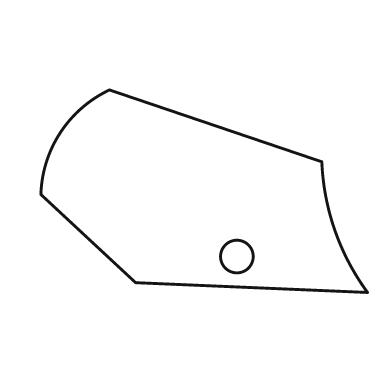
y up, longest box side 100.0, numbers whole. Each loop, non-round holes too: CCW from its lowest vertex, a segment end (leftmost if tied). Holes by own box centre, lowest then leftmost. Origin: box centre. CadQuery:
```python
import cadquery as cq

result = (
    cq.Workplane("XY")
    .moveTo(50.0, -31.0)
    .threePointArc((40.0, -12.0), (36.0, 9.0))
    .lineTo(-29.0, 31.0)
    .threePointArc((-44.0, 18.0), (-50.0, -1.0))
    .lineTo(-21.0, -28.0)
    .close()
    .moveTo(10.0, -20.0)
    .circle(5.0)
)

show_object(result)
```